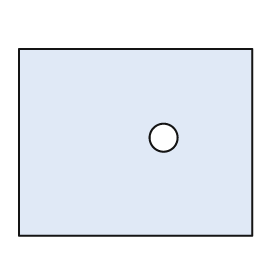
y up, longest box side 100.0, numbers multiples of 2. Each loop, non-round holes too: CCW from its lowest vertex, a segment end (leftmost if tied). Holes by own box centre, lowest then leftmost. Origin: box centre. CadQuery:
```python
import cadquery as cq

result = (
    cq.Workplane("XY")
    .moveTo(-50.0, -40.0)
    .lineTo(50.0, -40.0)
    .lineTo(50.0, 40.0)
    .lineTo(-50.0, 40.0)
    .close()
    .moveTo(12.0, 2.0)
    .circle(6.0)
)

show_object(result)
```